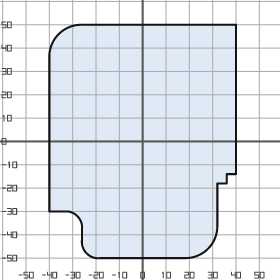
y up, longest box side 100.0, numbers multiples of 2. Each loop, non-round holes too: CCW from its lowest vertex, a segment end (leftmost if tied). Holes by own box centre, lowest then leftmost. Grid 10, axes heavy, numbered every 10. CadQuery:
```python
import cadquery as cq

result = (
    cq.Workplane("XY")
    .moveTo(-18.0, -50.0)
    .lineTo(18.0, -50.0)
    .threePointArc((28.0, -46.0), (32.0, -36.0))
    .lineTo(32.0, -18.0)
    .lineTo(36.0, -18.0)
    .lineTo(36.0, -14.0)
    .lineTo(40.0, -14.0)
    .lineTo(40.0, 50.0)
    .lineTo(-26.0, 50.0)
    .threePointArc((-36.0, 46.0), (-40.0, 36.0))
    .lineTo(-40.0, -30.0)
    .lineTo(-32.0, -30.0)
    .threePointArc((-28.0, -32.0), (-26.0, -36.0))
    .lineTo(-26.0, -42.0)
    .threePointArc((-24.0, -48.0), (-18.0, -50.0))
    .close()
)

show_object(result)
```